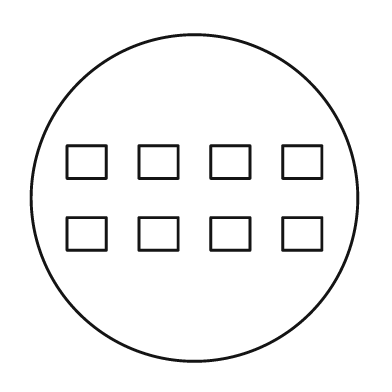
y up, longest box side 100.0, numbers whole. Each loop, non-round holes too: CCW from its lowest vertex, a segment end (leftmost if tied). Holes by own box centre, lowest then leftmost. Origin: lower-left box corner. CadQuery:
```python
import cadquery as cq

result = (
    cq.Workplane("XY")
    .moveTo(50.0, 50.0)
    .circle(50.0)
    .moveTo(11.0, 34.0)
    .lineTo(23.0, 34.0)
    .lineTo(23.0, 44.0)
    .lineTo(11.0, 44.0)
    .close()
    .moveTo(33.0, 34.0)
    .lineTo(45.0, 34.0)
    .lineTo(45.0, 44.0)
    .lineTo(33.0, 44.0)
    .close()
    .moveTo(55.0, 34.0)
    .lineTo(67.0, 34.0)
    .lineTo(67.0, 44.0)
    .lineTo(55.0, 44.0)
    .close()
    .moveTo(77.0, 34.0)
    .lineTo(89.0, 34.0)
    .lineTo(89.0, 44.0)
    .lineTo(77.0, 44.0)
    .close()
    .moveTo(11.0, 56.0)
    .lineTo(23.0, 56.0)
    .lineTo(23.0, 66.0)
    .lineTo(11.0, 66.0)
    .close()
    .moveTo(33.0, 56.0)
    .lineTo(45.0, 56.0)
    .lineTo(45.0, 66.0)
    .lineTo(33.0, 66.0)
    .close()
    .moveTo(55.0, 56.0)
    .lineTo(67.0, 56.0)
    .lineTo(67.0, 66.0)
    .lineTo(55.0, 66.0)
    .close()
    .moveTo(77.0, 56.0)
    .lineTo(89.0, 56.0)
    .lineTo(89.0, 66.0)
    .lineTo(77.0, 66.0)
    .close()
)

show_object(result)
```